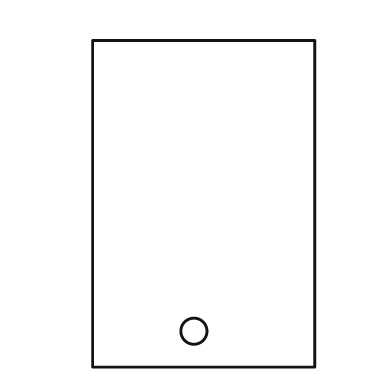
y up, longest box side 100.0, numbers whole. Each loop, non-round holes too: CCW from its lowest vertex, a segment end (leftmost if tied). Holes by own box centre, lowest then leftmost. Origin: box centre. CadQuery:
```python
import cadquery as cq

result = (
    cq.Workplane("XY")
    .moveTo(-34.0, -50.0)
    .lineTo(34.0, -50.0)
    .lineTo(34.0, 50.0)
    .lineTo(-34.0, 50.0)
    .close()
    .moveTo(-3.0, -39.0)
    .circle(4.0)
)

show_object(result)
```